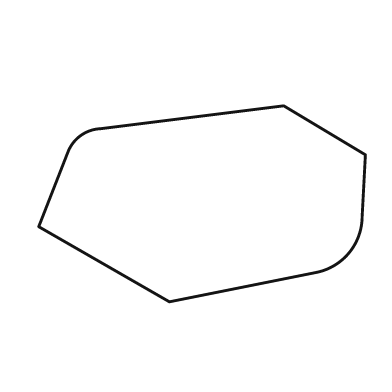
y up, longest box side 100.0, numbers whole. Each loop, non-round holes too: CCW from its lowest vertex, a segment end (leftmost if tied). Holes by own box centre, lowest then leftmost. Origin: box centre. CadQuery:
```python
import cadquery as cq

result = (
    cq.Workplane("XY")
    .moveTo(-10.0, -30.0)
    .lineTo(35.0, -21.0)
    .threePointArc((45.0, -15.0), (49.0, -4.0))
    .lineTo(50.0, 15.0)
    .lineTo(25.0, 30.0)
    .lineTo(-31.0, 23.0)
    .threePointArc((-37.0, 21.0), (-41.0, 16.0))
    .lineTo(-50.0, -7.0)
    .close()
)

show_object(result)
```